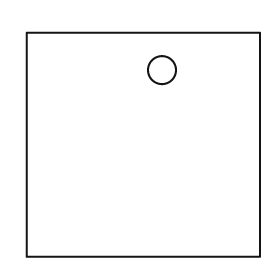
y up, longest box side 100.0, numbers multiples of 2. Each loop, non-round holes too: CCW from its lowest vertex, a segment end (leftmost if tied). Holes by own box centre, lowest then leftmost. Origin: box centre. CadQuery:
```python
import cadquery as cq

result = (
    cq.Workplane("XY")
    .moveTo(-50.0, -48.0)
    .lineTo(50.0, -48.0)
    .lineTo(50.0, 48.0)
    .lineTo(-50.0, 48.0)
    .close()
    .moveTo(8.0, 32.0)
    .circle(6.0)
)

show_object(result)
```